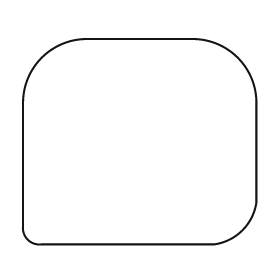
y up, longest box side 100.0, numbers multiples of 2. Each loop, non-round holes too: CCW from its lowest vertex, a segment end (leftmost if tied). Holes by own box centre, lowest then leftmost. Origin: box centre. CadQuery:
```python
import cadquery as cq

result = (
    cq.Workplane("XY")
    .moveTo(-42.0, -44.0)
    .lineTo(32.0, -44.0)
    .threePointArc((44.0, -38.0), (50.0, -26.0))
    .lineTo(50.0, 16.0)
    .threePointArc((42.0, 36.0), (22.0, 44.0))
    .lineTo(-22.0, 44.0)
    .threePointArc((-42.0, 36.0), (-50.0, 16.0))
    .lineTo(-50.0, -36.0)
    .threePointArc((-48.0, -42.0), (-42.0, -44.0))
    .close()
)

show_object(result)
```